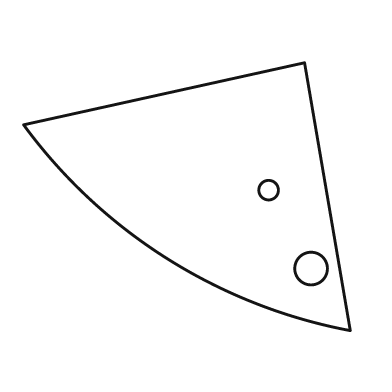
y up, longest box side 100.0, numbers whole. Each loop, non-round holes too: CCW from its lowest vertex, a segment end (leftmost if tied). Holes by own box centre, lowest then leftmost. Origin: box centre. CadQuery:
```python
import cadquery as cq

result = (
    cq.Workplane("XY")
    .moveTo(50.0, -41.0)
    .lineTo(36.0, 41.0)
    .lineTo(-50.0, 22.0)
    .threePointArc((-6.0, -19.0), (50.0, -41.0))
    .close()
    .moveTo(38.0, -22.0)
    .circle(5.0)
    .moveTo(25.0, 2.0)
    .circle(3.0)
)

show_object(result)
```